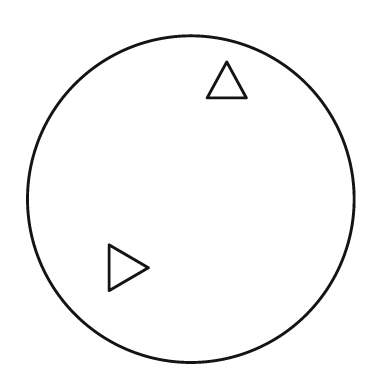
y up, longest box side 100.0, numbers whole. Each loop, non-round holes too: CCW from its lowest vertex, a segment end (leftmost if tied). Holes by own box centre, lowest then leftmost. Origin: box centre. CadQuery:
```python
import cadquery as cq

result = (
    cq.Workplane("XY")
    .moveTo(0.0, 0.0)
    .circle(50.0)
    .moveTo(-25.0, -28.0)
    .lineTo(-13.0, -21.0)
    .lineTo(-25.0, -14.0)
    .close()
    .moveTo(5.0, 31.0)
    .lineTo(17.0, 31.0)
    .lineTo(11.0, 42.0)
    .close()
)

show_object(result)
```